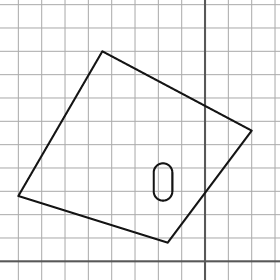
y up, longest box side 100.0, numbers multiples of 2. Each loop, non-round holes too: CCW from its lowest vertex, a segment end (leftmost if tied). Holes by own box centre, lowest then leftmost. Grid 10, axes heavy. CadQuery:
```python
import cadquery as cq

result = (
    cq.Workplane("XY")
    .moveTo(-16.0, 8.0)
    .lineTo(20.0, 56.0)
    .lineTo(-44.0, 90.0)
    .lineTo(-80.0, 28.0)
    .close()
    .moveTo(-22.0, 30.0)
    .threePointArc((-18.0, 26.0), (-14.0, 30.0))
    .lineTo(-14.0, 38.0)
    .threePointArc((-18.0, 42.0), (-22.0, 38.0))
    .close()
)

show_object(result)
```